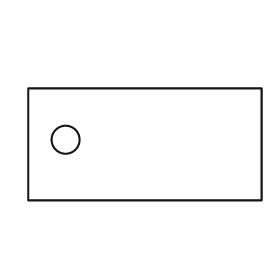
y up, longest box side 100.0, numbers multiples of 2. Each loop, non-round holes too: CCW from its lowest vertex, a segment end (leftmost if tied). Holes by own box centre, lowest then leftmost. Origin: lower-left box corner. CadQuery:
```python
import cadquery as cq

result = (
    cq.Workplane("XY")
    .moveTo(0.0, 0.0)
    .lineTo(100.0, 0.0)
    .lineTo(100.0, 48.0)
    .lineTo(0.0, 48.0)
    .close()
    .moveTo(16.0, 26.0)
    .circle(6.0)
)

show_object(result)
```